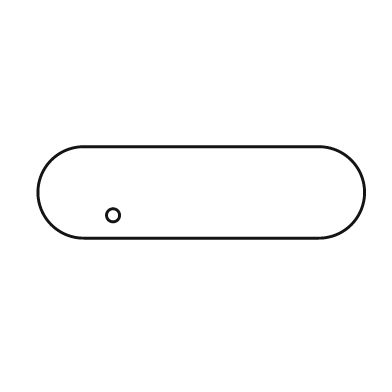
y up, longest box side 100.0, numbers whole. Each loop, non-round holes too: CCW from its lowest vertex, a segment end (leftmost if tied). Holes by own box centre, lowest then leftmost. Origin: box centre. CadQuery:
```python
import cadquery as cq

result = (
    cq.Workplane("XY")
    .moveTo(-36.0, -14.0)
    .lineTo(36.0, -14.0)
    .threePointArc((50.0, 0.0), (36.0, 14.0))
    .lineTo(-36.0, 14.0)
    .threePointArc((-50.0, 0.0), (-36.0, -14.0))
    .close()
    .moveTo(-27.0, -7.0)
    .circle(2.0)
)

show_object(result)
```